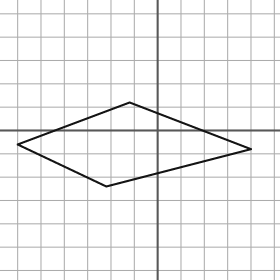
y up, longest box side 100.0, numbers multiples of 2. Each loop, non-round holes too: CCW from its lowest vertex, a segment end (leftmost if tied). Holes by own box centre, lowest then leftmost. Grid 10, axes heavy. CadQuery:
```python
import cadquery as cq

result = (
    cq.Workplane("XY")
    .moveTo(-22.0, -24.0)
    .lineTo(40.0, -8.0)
    .lineTo(-12.0, 12.0)
    .lineTo(-60.0, -6.0)
    .close()
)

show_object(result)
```